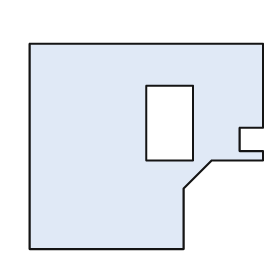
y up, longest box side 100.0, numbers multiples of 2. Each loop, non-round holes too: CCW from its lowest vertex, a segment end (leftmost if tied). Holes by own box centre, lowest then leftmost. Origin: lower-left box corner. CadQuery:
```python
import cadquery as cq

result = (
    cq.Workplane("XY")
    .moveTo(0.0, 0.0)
    .lineTo(66.0, 0.0)
    .lineTo(66.0, 26.0)
    .lineTo(78.0, 38.0)
    .lineTo(100.0, 38.0)
    .lineTo(100.0, 42.0)
    .lineTo(90.0, 42.0)
    .lineTo(90.0, 52.0)
    .lineTo(100.0, 52.0)
    .lineTo(100.0, 88.0)
    .lineTo(0.0, 88.0)
    .close()
    .moveTo(50.0, 38.0)
    .lineTo(70.0, 38.0)
    .lineTo(70.0, 70.0)
    .lineTo(50.0, 70.0)
    .close()
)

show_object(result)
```